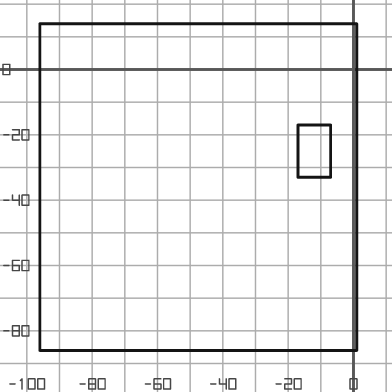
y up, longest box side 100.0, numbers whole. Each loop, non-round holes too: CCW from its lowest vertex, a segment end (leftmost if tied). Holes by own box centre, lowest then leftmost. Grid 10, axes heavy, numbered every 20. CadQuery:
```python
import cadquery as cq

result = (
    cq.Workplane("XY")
    .moveTo(-96.0, -86.0)
    .lineTo(1.0, -86.0)
    .lineTo(1.0, 14.0)
    .lineTo(-96.0, 14.0)
    .close()
    .moveTo(-17.0, -33.0)
    .lineTo(-7.0, -33.0)
    .lineTo(-7.0, -17.0)
    .lineTo(-17.0, -17.0)
    .close()
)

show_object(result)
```